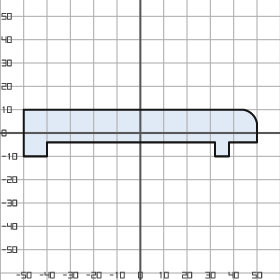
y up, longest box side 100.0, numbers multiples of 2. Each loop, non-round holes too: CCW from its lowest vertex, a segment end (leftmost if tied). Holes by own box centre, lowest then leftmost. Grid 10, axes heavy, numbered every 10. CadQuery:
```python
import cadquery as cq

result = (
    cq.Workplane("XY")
    .moveTo(-50.0, -10.0)
    .lineTo(-40.0, -10.0)
    .lineTo(-40.0, -4.0)
    .lineTo(32.0, -4.0)
    .lineTo(32.0, -10.0)
    .lineTo(38.0, -10.0)
    .lineTo(38.0, -4.0)
    .lineTo(50.0, -4.0)
    .lineTo(50.0, 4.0)
    .threePointArc((48.0, 8.0), (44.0, 10.0))
    .lineTo(-50.0, 10.0)
    .close()
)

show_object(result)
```